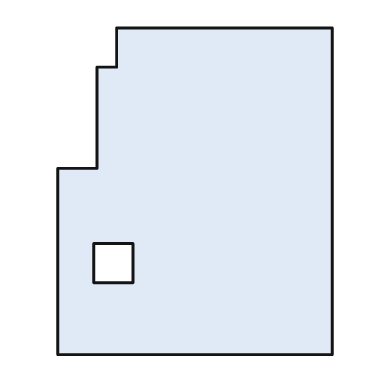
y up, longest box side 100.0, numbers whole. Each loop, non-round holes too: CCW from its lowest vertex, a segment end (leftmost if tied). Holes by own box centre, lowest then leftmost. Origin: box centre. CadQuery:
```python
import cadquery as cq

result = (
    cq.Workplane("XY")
    .moveTo(-42.0, -50.0)
    .lineTo(42.0, -50.0)
    .lineTo(42.0, 50.0)
    .lineTo(-24.0, 50.0)
    .lineTo(-24.0, 38.0)
    .lineTo(-30.0, 38.0)
    .lineTo(-30.0, 7.0)
    .lineTo(-42.0, 7.0)
    .close()
    .moveTo(-31.0, -28.0)
    .lineTo(-19.0, -28.0)
    .lineTo(-19.0, -16.0)
    .lineTo(-31.0, -16.0)
    .close()
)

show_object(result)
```